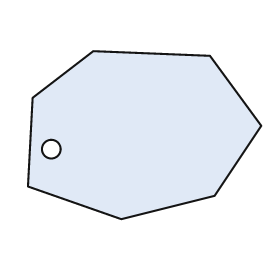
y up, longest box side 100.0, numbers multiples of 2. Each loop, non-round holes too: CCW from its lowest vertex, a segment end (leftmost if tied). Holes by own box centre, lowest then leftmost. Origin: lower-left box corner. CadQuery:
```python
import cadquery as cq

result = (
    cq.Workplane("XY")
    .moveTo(40.0, 0.0)
    .lineTo(80.0, 10.0)
    .lineTo(100.0, 40.0)
    .lineTo(78.0, 70.0)
    .lineTo(28.0, 72.0)
    .lineTo(2.0, 52.0)
    .lineTo(0.0, 14.0)
    .close()
    .moveTo(10.0, 30.0)
    .circle(4.0)
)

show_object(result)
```